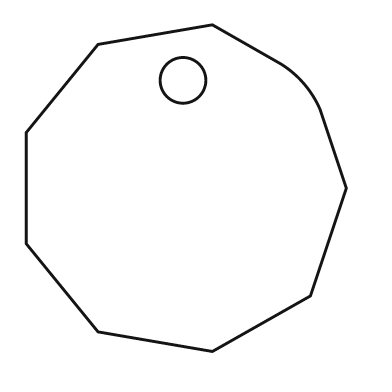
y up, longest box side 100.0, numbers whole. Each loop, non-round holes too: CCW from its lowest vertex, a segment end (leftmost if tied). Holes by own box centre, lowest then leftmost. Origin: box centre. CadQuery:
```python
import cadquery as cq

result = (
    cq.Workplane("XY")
    .moveTo(8.0, -50.0)
    .lineTo(38.0, -33.0)
    .lineTo(49.0, 0.0)
    .lineTo(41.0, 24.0)
    .threePointArc((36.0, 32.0), (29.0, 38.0))
    .lineTo(8.0, 50.0)
    .lineTo(-27.0, 44.0)
    .lineTo(-49.0, 17.0)
    .lineTo(-49.0, -17.0)
    .lineTo(-27.0, -44.0)
    .close()
    .moveTo(-1.0, 33.0)
    .circle(7.0)
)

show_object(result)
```